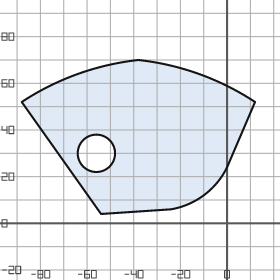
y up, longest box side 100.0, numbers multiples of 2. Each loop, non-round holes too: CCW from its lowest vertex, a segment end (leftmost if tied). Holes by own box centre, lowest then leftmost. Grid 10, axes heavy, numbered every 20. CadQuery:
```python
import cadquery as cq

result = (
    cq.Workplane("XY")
    .moveTo(-54.0, 4.0)
    .lineTo(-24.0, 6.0)
    .threePointArc((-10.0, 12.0), (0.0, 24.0))
    .lineTo(12.0, 52.0)
    .threePointArc((-12.0, 64.0), (-38.0, 70.0))
    .threePointArc((-64.0, 64.0), (-88.0, 52.0))
    .close()
    .moveTo(-56.0, 30.0)
    .circle(8.0)
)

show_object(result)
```